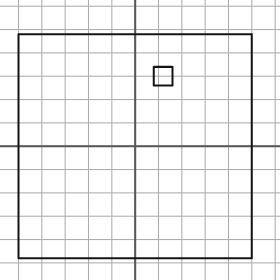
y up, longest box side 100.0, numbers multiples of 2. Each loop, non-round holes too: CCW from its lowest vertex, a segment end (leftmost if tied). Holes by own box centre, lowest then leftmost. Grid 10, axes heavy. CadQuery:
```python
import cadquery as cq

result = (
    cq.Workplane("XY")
    .moveTo(-50.0, -48.0)
    .lineTo(50.0, -48.0)
    .lineTo(50.0, 48.0)
    .lineTo(-50.0, 48.0)
    .close()
    .moveTo(8.0, 26.0)
    .lineTo(16.0, 26.0)
    .lineTo(16.0, 34.0)
    .lineTo(8.0, 34.0)
    .close()
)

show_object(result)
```